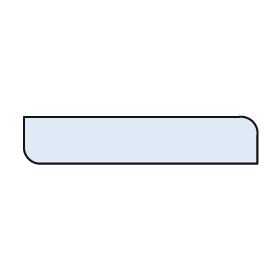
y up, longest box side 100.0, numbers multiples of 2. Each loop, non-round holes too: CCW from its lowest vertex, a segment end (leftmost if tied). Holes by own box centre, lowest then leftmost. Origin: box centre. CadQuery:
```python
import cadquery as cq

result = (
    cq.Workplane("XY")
    .moveTo(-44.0, -10.0)
    .lineTo(50.0, -10.0)
    .lineTo(50.0, 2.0)
    .threePointArc((48.0, 8.0), (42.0, 10.0))
    .lineTo(-50.0, 10.0)
    .lineTo(-50.0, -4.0)
    .threePointArc((-48.0, -8.0), (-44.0, -10.0))
    .close()
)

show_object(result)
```